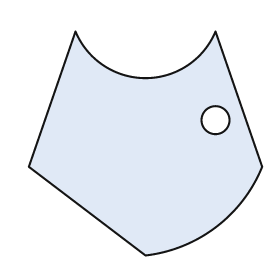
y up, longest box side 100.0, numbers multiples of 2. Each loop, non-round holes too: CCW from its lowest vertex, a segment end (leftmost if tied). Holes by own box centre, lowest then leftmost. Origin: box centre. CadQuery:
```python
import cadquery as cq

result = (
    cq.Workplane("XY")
    .moveTo(0.0, -48.0)
    .threePointArc((30.0, -36.0), (50.0, -10.0))
    .lineTo(30.0, 48.0)
    .threePointArc((0.0, 28.0), (-30.0, 48.0))
    .lineTo(-50.0, -10.0)
    .close()
    .moveTo(30.0, 10.0)
    .circle(6.0)
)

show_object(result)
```